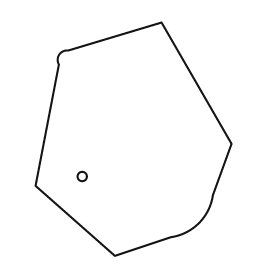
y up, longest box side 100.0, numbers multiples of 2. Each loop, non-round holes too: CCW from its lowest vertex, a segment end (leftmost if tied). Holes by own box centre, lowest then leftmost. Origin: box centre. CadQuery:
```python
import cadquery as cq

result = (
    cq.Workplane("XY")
    .moveTo(-8.0, -50.0)
    .lineTo(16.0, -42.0)
    .threePointArc((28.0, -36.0), (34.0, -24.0))
    .lineTo(42.0, -2.0)
    .lineTo(12.0, 50.0)
    .lineTo(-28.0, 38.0)
    .threePointArc((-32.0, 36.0), (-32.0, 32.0))
    .lineTo(-42.0, -20.0)
    .close()
    .moveTo(-22.0, -16.0)
    .circle(2.0)
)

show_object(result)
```